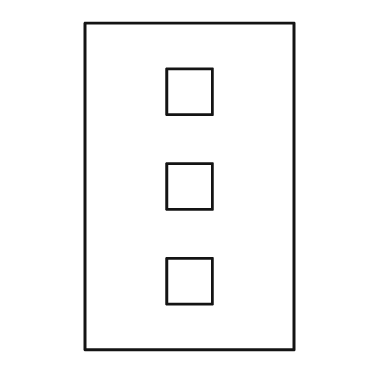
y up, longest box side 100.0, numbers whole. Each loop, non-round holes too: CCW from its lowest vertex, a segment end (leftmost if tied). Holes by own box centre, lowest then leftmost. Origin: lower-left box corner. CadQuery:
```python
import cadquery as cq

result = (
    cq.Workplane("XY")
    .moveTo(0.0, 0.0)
    .lineTo(64.0, 0.0)
    .lineTo(64.0, 100.0)
    .lineTo(0.0, 100.0)
    .close()
    .moveTo(25.0, 14.0)
    .lineTo(39.0, 14.0)
    .lineTo(39.0, 28.0)
    .lineTo(25.0, 28.0)
    .close()
    .moveTo(25.0, 43.0)
    .lineTo(39.0, 43.0)
    .lineTo(39.0, 57.0)
    .lineTo(25.0, 57.0)
    .close()
    .moveTo(25.0, 72.0)
    .lineTo(39.0, 72.0)
    .lineTo(39.0, 86.0)
    .lineTo(25.0, 86.0)
    .close()
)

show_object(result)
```